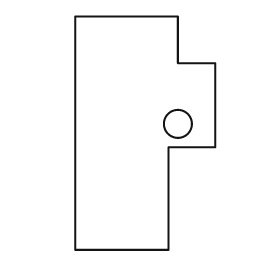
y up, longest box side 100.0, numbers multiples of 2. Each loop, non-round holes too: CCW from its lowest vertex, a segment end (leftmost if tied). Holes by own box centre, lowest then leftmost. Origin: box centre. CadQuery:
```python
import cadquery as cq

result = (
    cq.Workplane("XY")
    .moveTo(-30.0, -50.0)
    .lineTo(10.0, -50.0)
    .lineTo(10.0, -6.0)
    .lineTo(30.0, -6.0)
    .lineTo(30.0, 30.0)
    .lineTo(14.0, 30.0)
    .lineTo(14.0, 50.0)
    .lineTo(-30.0, 50.0)
    .close()
    .moveTo(14.0, 4.0)
    .circle(6.0)
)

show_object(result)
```